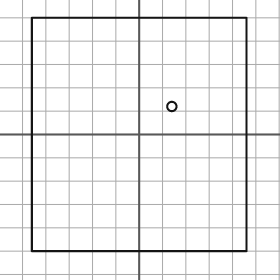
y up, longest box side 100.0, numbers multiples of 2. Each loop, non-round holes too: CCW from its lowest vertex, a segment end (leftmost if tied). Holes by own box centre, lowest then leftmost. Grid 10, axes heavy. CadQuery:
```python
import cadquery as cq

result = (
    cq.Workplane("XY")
    .moveTo(-46.0, -50.0)
    .lineTo(46.0, -50.0)
    .lineTo(46.0, 50.0)
    .lineTo(-46.0, 50.0)
    .close()
    .moveTo(14.0, 12.0)
    .circle(2.0)
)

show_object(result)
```